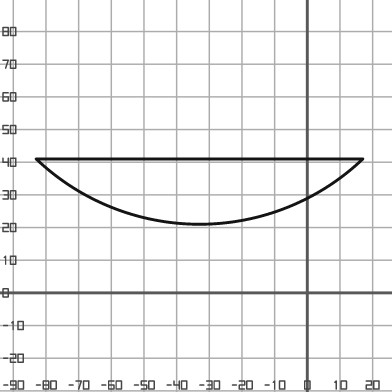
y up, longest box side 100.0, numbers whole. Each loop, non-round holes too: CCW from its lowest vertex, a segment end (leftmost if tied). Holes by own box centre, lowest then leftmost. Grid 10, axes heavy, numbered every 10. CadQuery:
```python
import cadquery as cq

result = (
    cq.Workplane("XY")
    .moveTo(-83.0, 41.0)
    .threePointArc((-33.0, 21.0), (17.0, 41.0))
    .close()
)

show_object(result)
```